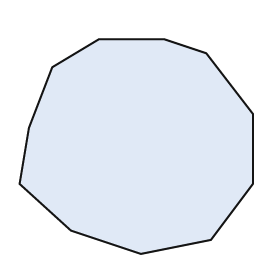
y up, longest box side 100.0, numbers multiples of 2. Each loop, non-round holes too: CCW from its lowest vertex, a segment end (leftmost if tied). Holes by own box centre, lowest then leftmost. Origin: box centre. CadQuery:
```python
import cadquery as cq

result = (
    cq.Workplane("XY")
    .moveTo(2.0, -46.0)
    .lineTo(32.0, -40.0)
    .lineTo(50.0, -16.0)
    .lineTo(50.0, 14.0)
    .lineTo(30.0, 40.0)
    .lineTo(12.0, 46.0)
    .lineTo(-16.0, 46.0)
    .lineTo(-36.0, 34.0)
    .lineTo(-46.0, 8.0)
    .lineTo(-50.0, -16.0)
    .lineTo(-28.0, -36.0)
    .close()
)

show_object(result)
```